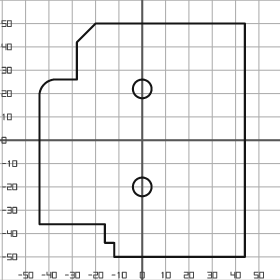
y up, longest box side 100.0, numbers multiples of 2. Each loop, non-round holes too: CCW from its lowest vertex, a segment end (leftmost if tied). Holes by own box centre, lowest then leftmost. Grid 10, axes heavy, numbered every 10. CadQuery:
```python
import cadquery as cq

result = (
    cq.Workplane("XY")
    .moveTo(-12.0, -50.0)
    .lineTo(44.0, -50.0)
    .lineTo(44.0, 50.0)
    .lineTo(-20.0, 50.0)
    .lineTo(-28.0, 42.0)
    .lineTo(-28.0, 26.0)
    .lineTo(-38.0, 26.0)
    .threePointArc((-42.0, 24.0), (-44.0, 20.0))
    .lineTo(-44.0, -36.0)
    .lineTo(-16.0, -36.0)
    .lineTo(-16.0, -44.0)
    .lineTo(-12.0, -44.0)
    .close()
    .moveTo(0.0, -20.0)
    .circle(4.0)
    .moveTo(0.0, 22.0)
    .circle(4.0)
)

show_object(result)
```